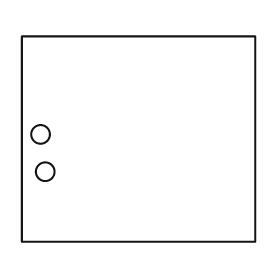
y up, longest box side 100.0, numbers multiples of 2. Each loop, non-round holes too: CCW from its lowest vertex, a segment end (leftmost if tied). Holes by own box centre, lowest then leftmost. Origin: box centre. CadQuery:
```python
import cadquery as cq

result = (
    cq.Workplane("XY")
    .moveTo(-50.0, -44.0)
    .lineTo(50.0, -44.0)
    .lineTo(50.0, 44.0)
    .lineTo(-50.0, 44.0)
    .close()
    .moveTo(-40.0, -14.0)
    .circle(4.0)
    .moveTo(-42.0, 2.0)
    .circle(4.0)
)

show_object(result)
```